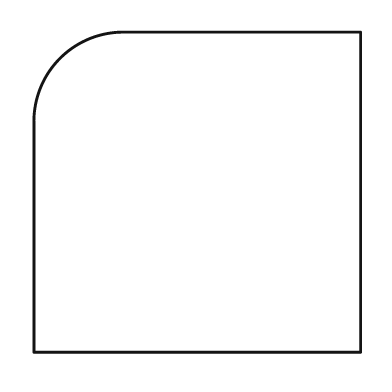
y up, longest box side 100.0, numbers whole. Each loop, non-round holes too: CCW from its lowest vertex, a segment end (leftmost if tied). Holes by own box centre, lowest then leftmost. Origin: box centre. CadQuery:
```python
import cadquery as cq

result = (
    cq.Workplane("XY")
    .moveTo(-50.0, -49.0)
    .lineTo(50.0, -49.0)
    .lineTo(50.0, 49.0)
    .lineTo(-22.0, 49.0)
    .threePointArc((-42.0, 41.0), (-50.0, 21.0))
    .close()
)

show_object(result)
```